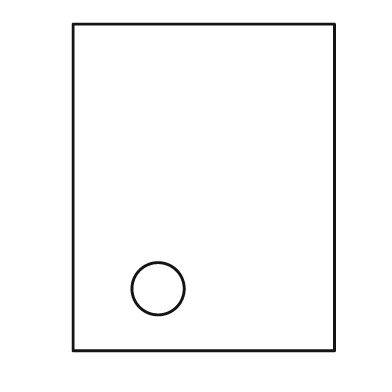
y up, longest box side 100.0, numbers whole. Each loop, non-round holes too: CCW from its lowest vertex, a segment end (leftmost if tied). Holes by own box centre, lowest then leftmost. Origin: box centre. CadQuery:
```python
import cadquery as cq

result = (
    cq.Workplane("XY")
    .moveTo(-40.0, -50.0)
    .lineTo(40.0, -50.0)
    .lineTo(40.0, 50.0)
    .lineTo(-40.0, 50.0)
    .close()
    .moveTo(-14.0, -31.0)
    .circle(8.0)
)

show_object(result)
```